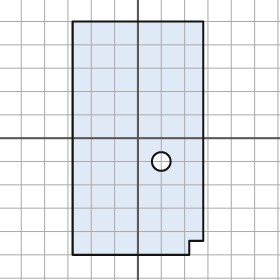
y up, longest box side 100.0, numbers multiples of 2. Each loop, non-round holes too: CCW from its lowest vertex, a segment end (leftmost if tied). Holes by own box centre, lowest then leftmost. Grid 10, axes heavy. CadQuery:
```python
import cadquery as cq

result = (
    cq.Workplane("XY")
    .moveTo(-28.0, -50.0)
    .lineTo(22.0, -50.0)
    .lineTo(22.0, -44.0)
    .lineTo(28.0, -44.0)
    .lineTo(28.0, 50.0)
    .lineTo(-28.0, 50.0)
    .close()
    .moveTo(10.0, -10.0)
    .circle(4.0)
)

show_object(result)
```